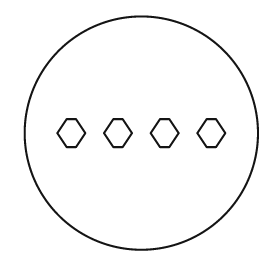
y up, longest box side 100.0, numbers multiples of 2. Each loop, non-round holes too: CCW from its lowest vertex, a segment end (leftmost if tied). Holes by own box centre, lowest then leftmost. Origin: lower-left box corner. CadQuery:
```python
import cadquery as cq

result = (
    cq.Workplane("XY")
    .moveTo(50.0, 50.0)
    .circle(50.0)
    .moveTo(18.0, 44.0)
    .lineTo(22.0, 44.0)
    .lineTo(26.0, 50.0)
    .lineTo(22.0, 56.0)
    .lineTo(18.0, 56.0)
    .lineTo(14.0, 50.0)
    .close()
    .moveTo(38.0, 44.0)
    .lineTo(42.0, 44.0)
    .lineTo(46.0, 50.0)
    .lineTo(42.0, 56.0)
    .lineTo(38.0, 56.0)
    .lineTo(34.0, 50.0)
    .close()
    .moveTo(58.0, 44.0)
    .lineTo(62.0, 44.0)
    .lineTo(66.0, 50.0)
    .lineTo(62.0, 56.0)
    .lineTo(58.0, 56.0)
    .lineTo(54.0, 50.0)
    .close()
    .moveTo(78.0, 44.0)
    .lineTo(82.0, 44.0)
    .lineTo(86.0, 50.0)
    .lineTo(82.0, 56.0)
    .lineTo(78.0, 56.0)
    .lineTo(74.0, 50.0)
    .close()
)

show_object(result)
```